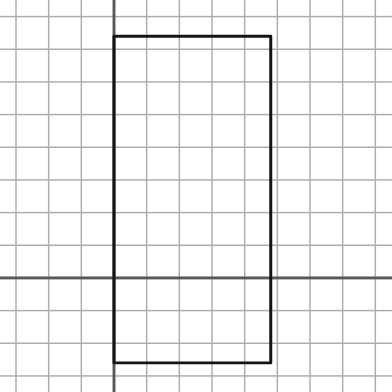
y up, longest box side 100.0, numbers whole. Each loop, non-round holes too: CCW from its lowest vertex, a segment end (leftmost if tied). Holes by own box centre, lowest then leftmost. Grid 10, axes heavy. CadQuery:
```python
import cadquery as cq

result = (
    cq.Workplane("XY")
    .moveTo(0.0, -26.0)
    .lineTo(48.0, -26.0)
    .lineTo(48.0, 74.0)
    .lineTo(0.0, 74.0)
    .close()
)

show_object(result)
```